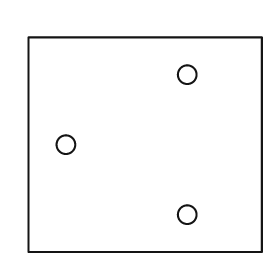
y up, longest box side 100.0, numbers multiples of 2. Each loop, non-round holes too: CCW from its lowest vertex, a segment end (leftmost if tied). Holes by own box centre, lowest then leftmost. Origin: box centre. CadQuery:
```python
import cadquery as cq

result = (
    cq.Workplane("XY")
    .moveTo(-50.0, -46.0)
    .lineTo(50.0, -46.0)
    .lineTo(50.0, 46.0)
    .lineTo(-50.0, 46.0)
    .close()
    .moveTo(18.0, -30.0)
    .circle(4.0)
    .moveTo(-34.0, 0.0)
    .circle(4.0)
    .moveTo(18.0, 30.0)
    .circle(4.0)
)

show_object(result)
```